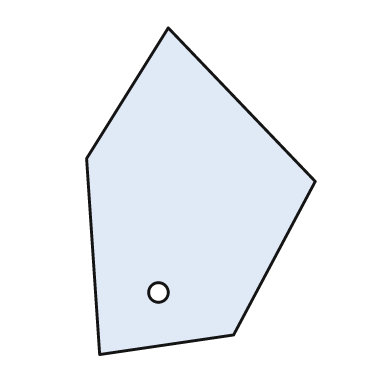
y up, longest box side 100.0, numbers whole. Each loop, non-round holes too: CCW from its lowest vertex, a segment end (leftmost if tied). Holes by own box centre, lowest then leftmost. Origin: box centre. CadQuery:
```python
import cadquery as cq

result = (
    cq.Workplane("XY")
    .moveTo(-31.0, -50.0)
    .lineTo(10.0, -44.0)
    .lineTo(35.0, 3.0)
    .lineTo(-10.0, 50.0)
    .lineTo(-35.0, 10.0)
    .close()
    .moveTo(-13.0, -31.0)
    .circle(3.0)
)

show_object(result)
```